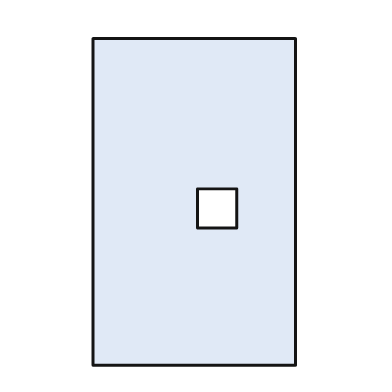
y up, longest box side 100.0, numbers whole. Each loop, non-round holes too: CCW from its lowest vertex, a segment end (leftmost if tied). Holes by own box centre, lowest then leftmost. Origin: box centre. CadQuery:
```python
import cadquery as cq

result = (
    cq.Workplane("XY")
    .moveTo(-31.0, -50.0)
    .lineTo(31.0, -50.0)
    .lineTo(31.0, 50.0)
    .lineTo(-31.0, 50.0)
    .close()
    .moveTo(1.0, -8.0)
    .lineTo(13.0, -8.0)
    .lineTo(13.0, 4.0)
    .lineTo(1.0, 4.0)
    .close()
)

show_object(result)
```